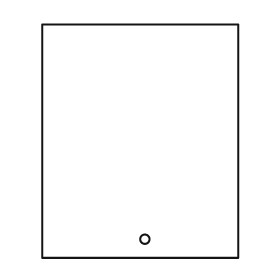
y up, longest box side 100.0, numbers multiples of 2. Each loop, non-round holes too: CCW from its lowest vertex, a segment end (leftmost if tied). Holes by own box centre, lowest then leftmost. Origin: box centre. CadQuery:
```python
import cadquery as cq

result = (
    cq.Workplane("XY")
    .moveTo(-42.0, -50.0)
    .lineTo(42.0, -50.0)
    .lineTo(42.0, 50.0)
    .lineTo(-42.0, 50.0)
    .close()
    .moveTo(2.0, -42.0)
    .circle(2.0)
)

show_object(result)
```